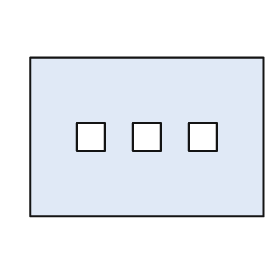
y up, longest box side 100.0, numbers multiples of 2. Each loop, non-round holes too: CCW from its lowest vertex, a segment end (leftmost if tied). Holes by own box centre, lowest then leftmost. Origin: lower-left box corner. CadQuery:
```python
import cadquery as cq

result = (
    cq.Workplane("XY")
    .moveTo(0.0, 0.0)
    .lineTo(100.0, 0.0)
    .lineTo(100.0, 68.0)
    .lineTo(0.0, 68.0)
    .close()
    .moveTo(20.0, 28.0)
    .lineTo(32.0, 28.0)
    .lineTo(32.0, 40.0)
    .lineTo(20.0, 40.0)
    .close()
    .moveTo(44.0, 28.0)
    .lineTo(56.0, 28.0)
    .lineTo(56.0, 40.0)
    .lineTo(44.0, 40.0)
    .close()
    .moveTo(68.0, 28.0)
    .lineTo(80.0, 28.0)
    .lineTo(80.0, 40.0)
    .lineTo(68.0, 40.0)
    .close()
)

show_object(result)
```